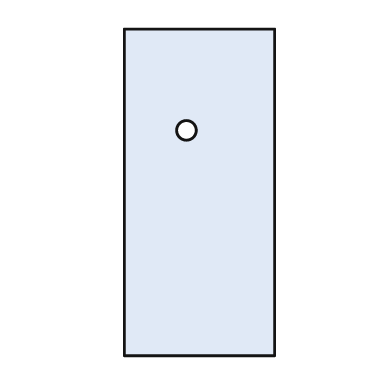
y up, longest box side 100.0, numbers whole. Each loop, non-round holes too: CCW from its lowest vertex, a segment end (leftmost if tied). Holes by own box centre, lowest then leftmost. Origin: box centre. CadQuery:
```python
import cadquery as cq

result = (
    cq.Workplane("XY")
    .moveTo(-23.0, -50.0)
    .lineTo(23.0, -50.0)
    .lineTo(23.0, 50.0)
    .lineTo(-23.0, 50.0)
    .close()
    .moveTo(-4.0, 19.0)
    .circle(3.0)
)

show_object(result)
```